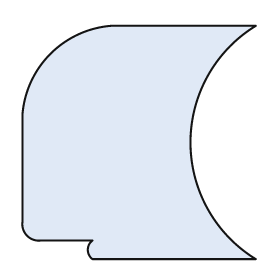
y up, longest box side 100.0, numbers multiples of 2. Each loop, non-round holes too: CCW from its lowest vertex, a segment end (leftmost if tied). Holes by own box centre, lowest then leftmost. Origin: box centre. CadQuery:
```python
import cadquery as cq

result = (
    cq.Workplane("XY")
    .moveTo(-20.0, -50.0)
    .lineTo(50.0, -50.0)
    .threePointArc((22.0, 0.0), (50.0, 50.0))
    .lineTo(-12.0, 50.0)
    .threePointArc((-38.0, 38.0), (-50.0, 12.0))
    .lineTo(-50.0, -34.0)
    .threePointArc((-48.0, -40.0), (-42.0, -42.0))
    .lineTo(-20.0, -42.0)
    .threePointArc((-22.0, -46.0), (-20.0, -50.0))
    .close()
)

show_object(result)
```